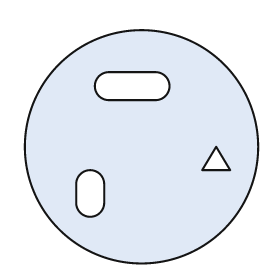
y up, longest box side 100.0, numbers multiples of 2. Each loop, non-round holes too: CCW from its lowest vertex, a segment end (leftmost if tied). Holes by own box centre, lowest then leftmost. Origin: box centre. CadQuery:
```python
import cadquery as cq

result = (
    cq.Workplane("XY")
    .moveTo(0.0, 0.0)
    .circle(50.0)
    .moveTo(-28.0, -24.0)
    .threePointArc((-22.0, -30.0), (-16.0, -24.0))
    .lineTo(-16.0, -16.0)
    .threePointArc((-22.0, -10.0), (-28.0, -16.0))
    .close()
    .moveTo(26.0, -10.0)
    .lineTo(38.0, -10.0)
    .lineTo(32.0, 0.0)
    .close()
    .moveTo(-14.0, 20.0)
    .lineTo(6.0, 20.0)
    .threePointArc((12.0, 26.0), (6.0, 32.0))
    .lineTo(-14.0, 32.0)
    .threePointArc((-20.0, 26.0), (-14.0, 20.0))
    .close()
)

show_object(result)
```